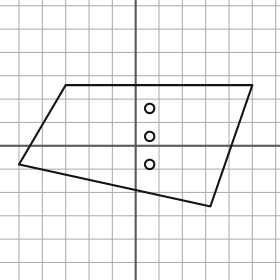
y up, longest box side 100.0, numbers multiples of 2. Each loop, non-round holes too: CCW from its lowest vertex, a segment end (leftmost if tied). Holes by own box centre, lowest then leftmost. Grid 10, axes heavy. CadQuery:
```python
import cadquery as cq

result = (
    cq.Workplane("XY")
    .moveTo(32.0, -26.0)
    .lineTo(50.0, 26.0)
    .lineTo(-30.0, 26.0)
    .lineTo(-50.0, -8.0)
    .close()
    .moveTo(6.0, -8.0)
    .circle(2.0)
    .moveTo(6.0, 4.0)
    .circle(2.0)
    .moveTo(6.0, 16.0)
    .circle(2.0)
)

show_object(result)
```